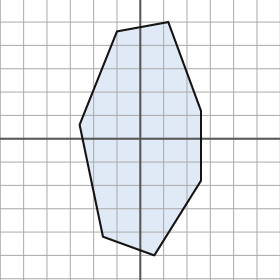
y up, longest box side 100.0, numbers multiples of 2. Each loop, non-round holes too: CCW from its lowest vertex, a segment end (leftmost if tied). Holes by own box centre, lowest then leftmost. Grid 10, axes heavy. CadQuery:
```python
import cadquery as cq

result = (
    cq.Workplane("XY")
    .moveTo(6.0, -50.0)
    .lineTo(26.0, -18.0)
    .lineTo(26.0, 12.0)
    .lineTo(12.0, 50.0)
    .lineTo(-10.0, 46.0)
    .lineTo(-26.0, 6.0)
    .lineTo(-16.0, -42.0)
    .close()
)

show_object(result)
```